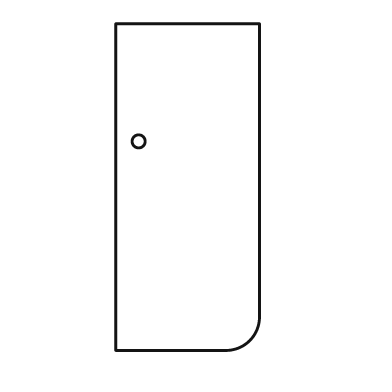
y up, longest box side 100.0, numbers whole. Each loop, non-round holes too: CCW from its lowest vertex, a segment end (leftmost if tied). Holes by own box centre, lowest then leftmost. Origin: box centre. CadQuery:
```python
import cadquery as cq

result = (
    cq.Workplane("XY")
    .moveTo(-22.0, -50.0)
    .lineTo(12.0, -50.0)
    .threePointArc((19.0, -47.0), (22.0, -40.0))
    .lineTo(22.0, 50.0)
    .lineTo(-22.0, 50.0)
    .close()
    .moveTo(-15.0, 14.0)
    .circle(2.0)
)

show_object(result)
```